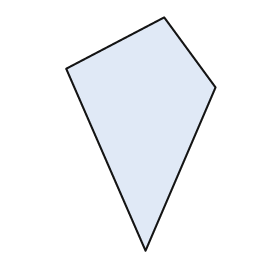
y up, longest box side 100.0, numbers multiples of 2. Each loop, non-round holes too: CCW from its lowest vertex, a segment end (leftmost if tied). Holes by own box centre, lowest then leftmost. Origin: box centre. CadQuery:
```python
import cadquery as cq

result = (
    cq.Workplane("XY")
    .moveTo(2.0, -50.0)
    .lineTo(32.0, 20.0)
    .lineTo(10.0, 50.0)
    .lineTo(-32.0, 28.0)
    .close()
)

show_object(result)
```